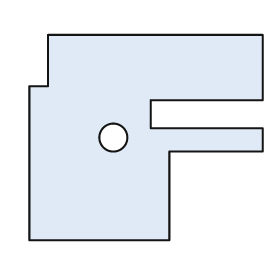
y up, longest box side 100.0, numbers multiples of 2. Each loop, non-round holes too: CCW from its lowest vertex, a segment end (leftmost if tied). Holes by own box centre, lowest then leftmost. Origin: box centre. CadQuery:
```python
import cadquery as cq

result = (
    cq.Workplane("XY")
    .moveTo(-50.0, -44.0)
    .lineTo(10.0, -44.0)
    .lineTo(10.0, -6.0)
    .lineTo(50.0, -6.0)
    .lineTo(50.0, 4.0)
    .lineTo(2.0, 4.0)
    .lineTo(2.0, 16.0)
    .lineTo(50.0, 16.0)
    .lineTo(50.0, 44.0)
    .lineTo(-42.0, 44.0)
    .lineTo(-42.0, 22.0)
    .lineTo(-50.0, 22.0)
    .close()
    .moveTo(-14.0, 0.0)
    .circle(6.0)
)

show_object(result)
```